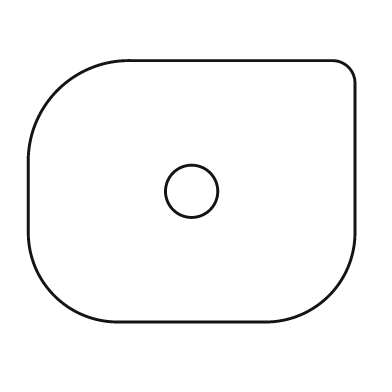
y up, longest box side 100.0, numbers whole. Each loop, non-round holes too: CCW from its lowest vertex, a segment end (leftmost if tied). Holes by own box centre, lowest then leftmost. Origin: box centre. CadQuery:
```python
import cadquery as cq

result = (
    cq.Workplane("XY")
    .moveTo(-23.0, -40.0)
    .lineTo(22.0, -40.0)
    .threePointArc((42.0, -32.0), (50.0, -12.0))
    .lineTo(50.0, 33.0)
    .threePointArc((48.0, 38.0), (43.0, 40.0))
    .lineTo(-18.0, 40.0)
    .threePointArc((-41.0, 31.0), (-50.0, 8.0))
    .lineTo(-50.0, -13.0)
    .threePointArc((-42.0, -32.0), (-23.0, -40.0))
    .close()
    .moveTo(0.0, 0.0)
    .circle(8.0)
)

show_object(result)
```